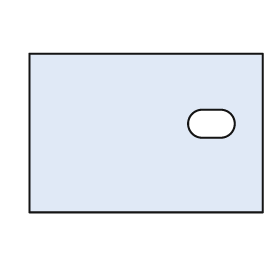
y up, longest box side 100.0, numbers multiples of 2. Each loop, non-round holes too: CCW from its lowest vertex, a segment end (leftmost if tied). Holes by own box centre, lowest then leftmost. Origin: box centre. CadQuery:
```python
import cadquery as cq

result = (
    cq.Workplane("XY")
    .moveTo(-50.0, -34.0)
    .lineTo(50.0, -34.0)
    .lineTo(50.0, 34.0)
    .lineTo(-50.0, 34.0)
    .close()
    .moveTo(24.0, -2.0)
    .lineTo(32.0, -2.0)
    .threePointArc((38.0, 4.0), (32.0, 10.0))
    .lineTo(24.0, 10.0)
    .threePointArc((18.0, 4.0), (24.0, -2.0))
    .close()
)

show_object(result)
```